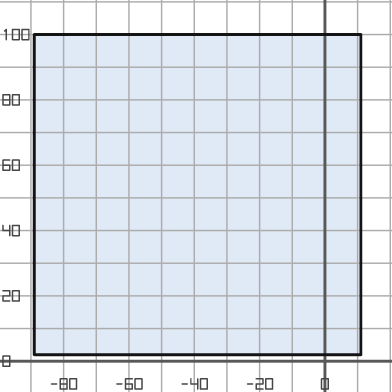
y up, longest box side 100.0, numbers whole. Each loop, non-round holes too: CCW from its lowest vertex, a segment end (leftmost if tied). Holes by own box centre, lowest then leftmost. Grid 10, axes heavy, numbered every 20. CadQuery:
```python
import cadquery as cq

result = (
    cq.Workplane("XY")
    .moveTo(-89.0, 2.0)
    .lineTo(11.0, 2.0)
    .lineTo(11.0, 100.0)
    .lineTo(-89.0, 100.0)
    .close()
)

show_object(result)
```